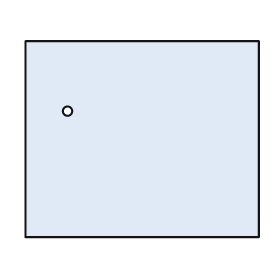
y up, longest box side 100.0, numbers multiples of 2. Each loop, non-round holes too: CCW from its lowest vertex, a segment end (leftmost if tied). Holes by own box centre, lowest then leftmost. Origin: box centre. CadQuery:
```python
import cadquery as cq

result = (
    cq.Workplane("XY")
    .moveTo(-50.0, -42.0)
    .lineTo(50.0, -42.0)
    .lineTo(50.0, 42.0)
    .lineTo(-50.0, 42.0)
    .close()
    .moveTo(-32.0, 12.0)
    .circle(2.0)
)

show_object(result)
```